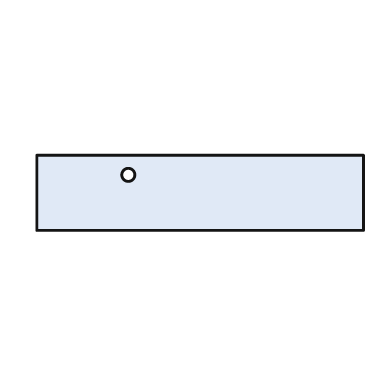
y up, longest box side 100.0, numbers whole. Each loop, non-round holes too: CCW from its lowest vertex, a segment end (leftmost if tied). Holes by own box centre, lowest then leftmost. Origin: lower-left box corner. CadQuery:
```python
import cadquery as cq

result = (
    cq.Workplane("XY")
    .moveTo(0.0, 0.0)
    .lineTo(100.0, 0.0)
    .lineTo(100.0, 23.0)
    .lineTo(0.0, 23.0)
    .close()
    .moveTo(28.0, 17.0)
    .circle(2.0)
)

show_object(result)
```